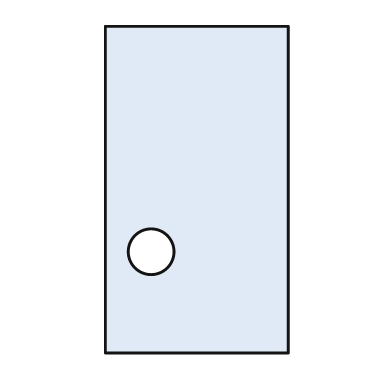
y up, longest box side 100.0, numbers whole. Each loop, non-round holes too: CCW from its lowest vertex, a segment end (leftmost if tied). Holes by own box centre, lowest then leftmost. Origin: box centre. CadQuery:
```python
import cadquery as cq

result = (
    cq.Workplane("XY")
    .moveTo(-28.0, -50.0)
    .lineTo(28.0, -50.0)
    .lineTo(28.0, 50.0)
    .lineTo(-28.0, 50.0)
    .close()
    .moveTo(-14.0, -19.0)
    .circle(7.0)
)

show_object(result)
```